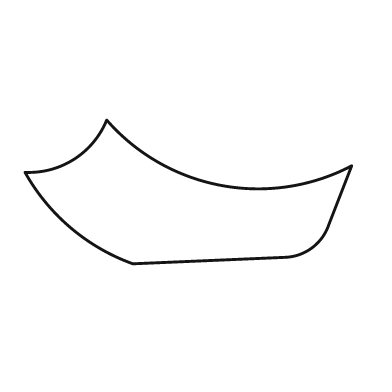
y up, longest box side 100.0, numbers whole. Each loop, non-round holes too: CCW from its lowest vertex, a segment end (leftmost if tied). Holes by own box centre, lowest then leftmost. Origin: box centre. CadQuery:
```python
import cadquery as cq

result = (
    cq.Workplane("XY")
    .moveTo(-17.0, -22.0)
    .lineTo(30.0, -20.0)
    .threePointArc((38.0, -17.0), (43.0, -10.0))
    .lineTo(50.0, 8.0)
    .threePointArc((10.0, 2.0), (-25.0, 22.0))
    .threePointArc((-35.0, 10.0), (-50.0, 6.0))
    .threePointArc((-36.0, -11.0), (-17.0, -22.0))
    .close()
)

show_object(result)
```